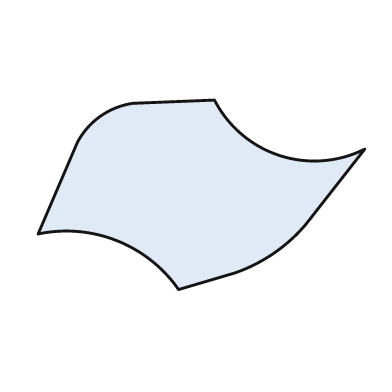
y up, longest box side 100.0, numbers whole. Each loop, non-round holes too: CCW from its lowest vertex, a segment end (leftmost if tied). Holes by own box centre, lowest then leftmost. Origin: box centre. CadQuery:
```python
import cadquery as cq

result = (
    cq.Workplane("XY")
    .moveTo(-7.0, -29.0)
    .lineTo(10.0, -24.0)
    .threePointArc((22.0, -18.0), (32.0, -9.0))
    .lineTo(50.0, 14.0)
    .threePointArc((24.0, 12.0), (4.0, 29.0))
    .lineTo(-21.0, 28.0)
    .threePointArc((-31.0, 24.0), (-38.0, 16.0))
    .lineTo(-50.0, -12.0)
    .threePointArc((-26.0, -14.0), (-7.0, -29.0))
    .close()
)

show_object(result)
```